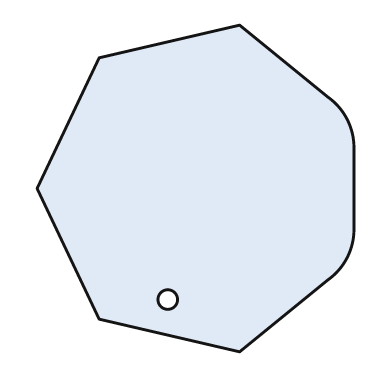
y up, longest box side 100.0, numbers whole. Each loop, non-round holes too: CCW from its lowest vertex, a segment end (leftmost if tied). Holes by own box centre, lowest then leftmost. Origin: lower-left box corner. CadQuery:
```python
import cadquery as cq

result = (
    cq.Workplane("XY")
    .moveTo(62.0, 0.0)
    .lineTo(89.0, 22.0)
    .threePointArc((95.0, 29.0), (97.0, 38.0))
    .lineTo(97.0, 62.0)
    .threePointArc((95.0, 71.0), (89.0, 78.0))
    .lineTo(62.0, 100.0)
    .lineTo(19.0, 90.0)
    .lineTo(0.0, 50.0)
    .lineTo(19.0, 10.0)
    .close()
    .moveTo(40.0, 16.0)
    .circle(3.0)
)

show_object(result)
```